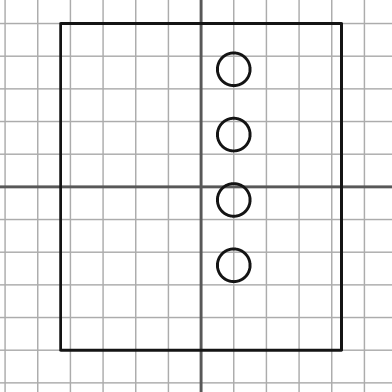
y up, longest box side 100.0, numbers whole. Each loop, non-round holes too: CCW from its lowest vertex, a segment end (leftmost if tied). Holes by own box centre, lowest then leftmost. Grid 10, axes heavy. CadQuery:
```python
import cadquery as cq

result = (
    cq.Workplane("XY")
    .moveTo(-43.0, -50.0)
    .lineTo(43.0, -50.0)
    .lineTo(43.0, 50.0)
    .lineTo(-43.0, 50.0)
    .close()
    .moveTo(10.0, -24.0)
    .circle(5.0)
    .moveTo(10.0, -4.0)
    .circle(5.0)
    .moveTo(10.0, 16.0)
    .circle(5.0)
    .moveTo(10.0, 36.0)
    .circle(5.0)
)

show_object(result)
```